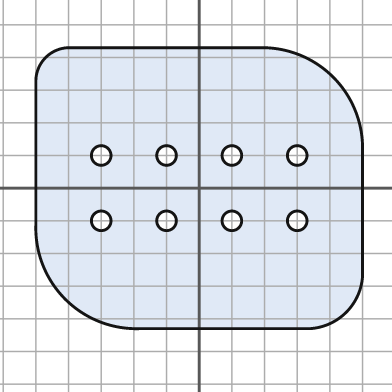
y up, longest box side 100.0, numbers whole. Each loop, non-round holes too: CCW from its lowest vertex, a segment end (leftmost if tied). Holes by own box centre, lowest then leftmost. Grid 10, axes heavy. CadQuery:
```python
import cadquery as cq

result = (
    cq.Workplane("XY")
    .moveTo(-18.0, -43.0)
    .lineTo(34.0, -43.0)
    .threePointArc((45.0, -38.0), (50.0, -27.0))
    .lineTo(50.0, 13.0)
    .threePointArc((41.0, 34.0), (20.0, 43.0))
    .lineTo(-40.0, 43.0)
    .threePointArc((-47.0, 40.0), (-50.0, 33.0))
    .lineTo(-50.0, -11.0)
    .threePointArc((-41.0, -34.0), (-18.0, -43.0))
    .close()
    .moveTo(-30.0, -10.0)
    .circle(3.0)
    .moveTo(-10.0, -10.0)
    .circle(3.0)
    .moveTo(10.0, -10.0)
    .circle(3.0)
    .moveTo(30.0, -10.0)
    .circle(3.0)
    .moveTo(-30.0, 10.0)
    .circle(3.0)
    .moveTo(-10.0, 10.0)
    .circle(3.0)
    .moveTo(10.0, 10.0)
    .circle(3.0)
    .moveTo(30.0, 10.0)
    .circle(3.0)
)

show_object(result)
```